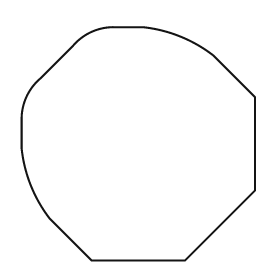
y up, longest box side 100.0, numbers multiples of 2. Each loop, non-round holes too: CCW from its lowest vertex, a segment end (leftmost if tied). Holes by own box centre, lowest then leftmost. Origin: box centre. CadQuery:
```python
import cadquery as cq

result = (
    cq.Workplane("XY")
    .moveTo(-20.0, -50.0)
    .lineTo(20.0, -50.0)
    .lineTo(50.0, -20.0)
    .lineTo(50.0, 20.0)
    .lineTo(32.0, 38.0)
    .threePointArc((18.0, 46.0), (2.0, 50.0))
    .lineTo(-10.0, 50.0)
    .threePointArc((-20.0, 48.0), (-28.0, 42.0))
    .lineTo(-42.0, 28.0)
    .threePointArc((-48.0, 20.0), (-50.0, 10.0))
    .lineTo(-50.0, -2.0)
    .threePointArc((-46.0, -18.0), (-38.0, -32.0))
    .close()
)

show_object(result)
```